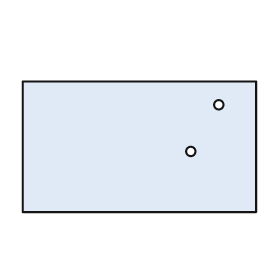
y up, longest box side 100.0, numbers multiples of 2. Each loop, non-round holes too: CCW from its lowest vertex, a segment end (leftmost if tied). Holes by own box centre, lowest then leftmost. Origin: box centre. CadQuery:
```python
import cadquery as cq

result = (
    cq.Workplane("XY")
    .moveTo(-50.0, -28.0)
    .lineTo(50.0, -28.0)
    .lineTo(50.0, 28.0)
    .lineTo(-50.0, 28.0)
    .close()
    .moveTo(22.0, -2.0)
    .circle(2.0)
    .moveTo(34.0, 18.0)
    .circle(2.0)
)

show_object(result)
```